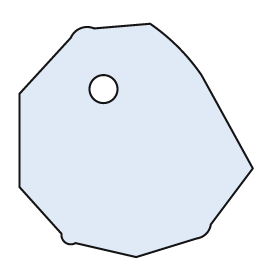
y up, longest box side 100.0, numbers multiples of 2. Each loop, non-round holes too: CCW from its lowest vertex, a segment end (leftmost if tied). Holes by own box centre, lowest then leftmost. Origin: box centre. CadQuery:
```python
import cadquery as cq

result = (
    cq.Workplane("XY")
    .moveTo(0.0, -50.0)
    .lineTo(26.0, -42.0)
    .threePointArc((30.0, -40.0), (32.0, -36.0))
    .lineTo(50.0, -12.0)
    .lineTo(28.0, 28.0)
    .threePointArc((18.0, 40.0), (6.0, 50.0))
    .lineTo(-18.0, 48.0)
    .threePointArc((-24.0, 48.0), (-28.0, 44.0))
    .lineTo(-50.0, 20.0)
    .lineTo(-50.0, -20.0)
    .lineTo(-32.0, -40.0)
    .threePointArc((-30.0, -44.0), (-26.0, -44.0))
    .close()
    .moveTo(-14.0, 22.0)
    .circle(6.0)
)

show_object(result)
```